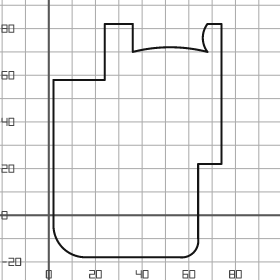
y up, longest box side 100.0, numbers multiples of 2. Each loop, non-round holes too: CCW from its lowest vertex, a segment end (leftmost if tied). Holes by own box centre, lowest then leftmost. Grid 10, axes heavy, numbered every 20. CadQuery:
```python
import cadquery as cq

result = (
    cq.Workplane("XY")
    .moveTo(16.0, -18.0)
    .lineTo(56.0, -18.0)
    .threePointArc((62.0, -16.0), (64.0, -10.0))
    .lineTo(64.0, 22.0)
    .lineTo(74.0, 22.0)
    .lineTo(74.0, 82.0)
    .lineTo(68.0, 82.0)
    .threePointArc((66.0, 76.0), (68.0, 70.0))
    .threePointArc((52.0, 72.0), (36.0, 70.0))
    .lineTo(36.0, 82.0)
    .lineTo(24.0, 82.0)
    .lineTo(24.0, 58.0)
    .lineTo(2.0, 58.0)
    .lineTo(2.0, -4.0)
    .threePointArc((6.0, -14.0), (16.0, -18.0))
    .close()
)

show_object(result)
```